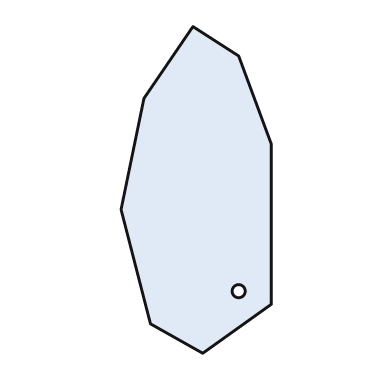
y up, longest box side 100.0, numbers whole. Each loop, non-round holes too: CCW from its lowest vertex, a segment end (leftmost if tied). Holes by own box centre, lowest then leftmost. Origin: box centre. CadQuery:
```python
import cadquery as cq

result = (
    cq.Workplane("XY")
    .moveTo(2.0, -50.0)
    .lineTo(23.0, -35.0)
    .lineTo(23.0, 14.0)
    .lineTo(13.0, 41.0)
    .lineTo(-1.0, 50.0)
    .lineTo(-16.0, 28.0)
    .lineTo(-23.0, -6.0)
    .lineTo(-14.0, -41.0)
    .close()
    .moveTo(13.0, -31.0)
    .circle(2.0)
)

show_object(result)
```